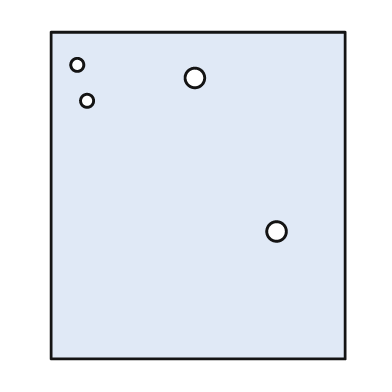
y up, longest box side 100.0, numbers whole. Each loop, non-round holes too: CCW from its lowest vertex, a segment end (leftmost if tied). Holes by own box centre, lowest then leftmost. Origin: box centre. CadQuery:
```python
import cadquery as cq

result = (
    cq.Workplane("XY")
    .moveTo(-45.0, -50.0)
    .lineTo(45.0, -50.0)
    .lineTo(45.0, 50.0)
    .lineTo(-45.0, 50.0)
    .close()
    .moveTo(24.0, -11.0)
    .circle(3.0)
    .moveTo(-34.0, 29.0)
    .circle(2.0)
    .moveTo(-1.0, 36.0)
    .circle(3.0)
    .moveTo(-37.0, 40.0)
    .circle(2.0)
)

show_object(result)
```